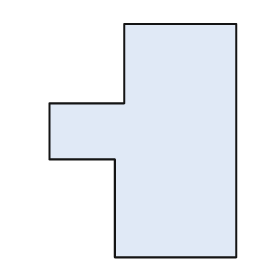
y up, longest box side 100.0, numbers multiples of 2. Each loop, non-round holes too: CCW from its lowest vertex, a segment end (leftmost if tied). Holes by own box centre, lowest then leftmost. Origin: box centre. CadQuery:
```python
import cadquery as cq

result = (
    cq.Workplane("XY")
    .moveTo(-12.0, -50.0)
    .lineTo(40.0, -50.0)
    .lineTo(40.0, 50.0)
    .lineTo(-8.0, 50.0)
    .lineTo(-8.0, 16.0)
    .lineTo(-40.0, 16.0)
    .lineTo(-40.0, -8.0)
    .lineTo(-12.0, -8.0)
    .close()
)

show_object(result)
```